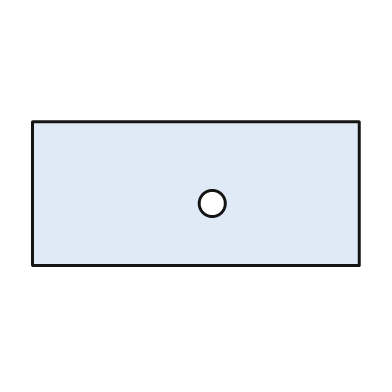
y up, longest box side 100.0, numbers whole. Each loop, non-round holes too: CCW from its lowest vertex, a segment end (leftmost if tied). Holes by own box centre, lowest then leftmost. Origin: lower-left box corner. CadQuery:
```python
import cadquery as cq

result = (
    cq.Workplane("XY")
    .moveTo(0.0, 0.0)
    .lineTo(100.0, 0.0)
    .lineTo(100.0, 44.0)
    .lineTo(0.0, 44.0)
    .close()
    .moveTo(55.0, 19.0)
    .circle(4.0)
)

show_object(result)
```